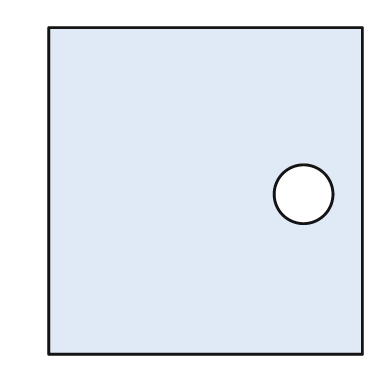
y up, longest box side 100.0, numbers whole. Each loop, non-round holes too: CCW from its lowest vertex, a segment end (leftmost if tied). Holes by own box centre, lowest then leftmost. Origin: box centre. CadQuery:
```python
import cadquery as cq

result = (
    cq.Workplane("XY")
    .moveTo(-48.0, -50.0)
    .lineTo(48.0, -50.0)
    .lineTo(48.0, 50.0)
    .lineTo(-48.0, 50.0)
    .close()
    .moveTo(30.0, -1.0)
    .circle(9.0)
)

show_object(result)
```